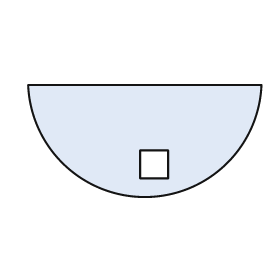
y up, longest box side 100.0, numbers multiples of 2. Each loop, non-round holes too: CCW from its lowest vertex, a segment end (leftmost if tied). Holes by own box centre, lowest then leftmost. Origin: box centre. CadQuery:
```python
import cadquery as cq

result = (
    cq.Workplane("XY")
    .moveTo(-50.0, 24.0)
    .threePointArc((0.0, -24.0), (50.0, 24.0))
    .close()
    .moveTo(-2.0, -16.0)
    .lineTo(10.0, -16.0)
    .lineTo(10.0, -4.0)
    .lineTo(-2.0, -4.0)
    .close()
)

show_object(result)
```